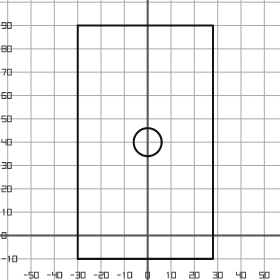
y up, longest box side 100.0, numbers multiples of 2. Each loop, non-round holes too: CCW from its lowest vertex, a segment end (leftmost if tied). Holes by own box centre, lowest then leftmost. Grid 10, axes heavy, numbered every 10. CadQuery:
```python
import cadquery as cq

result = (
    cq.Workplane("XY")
    .moveTo(-30.0, -10.0)
    .lineTo(28.0, -10.0)
    .lineTo(28.0, 90.0)
    .lineTo(-30.0, 90.0)
    .close()
    .moveTo(0.0, 40.0)
    .circle(6.0)
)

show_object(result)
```